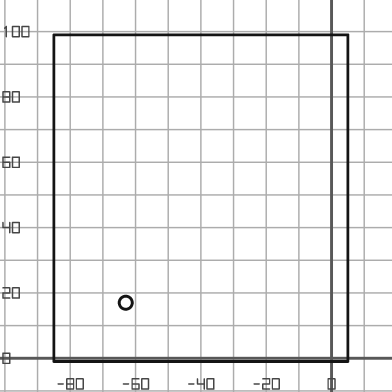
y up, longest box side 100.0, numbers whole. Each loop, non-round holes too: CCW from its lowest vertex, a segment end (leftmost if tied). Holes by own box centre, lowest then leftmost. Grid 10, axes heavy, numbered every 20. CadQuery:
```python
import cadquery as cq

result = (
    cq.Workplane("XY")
    .moveTo(-85.0, -1.0)
    .lineTo(5.0, -1.0)
    .lineTo(5.0, 99.0)
    .lineTo(-85.0, 99.0)
    .close()
    .moveTo(-63.0, 17.0)
    .circle(2.0)
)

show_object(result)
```